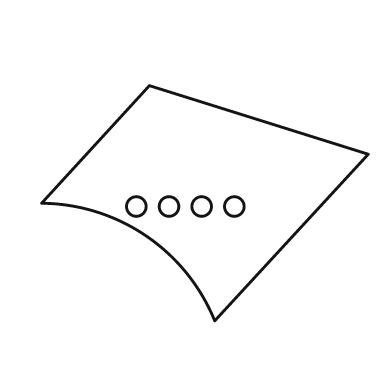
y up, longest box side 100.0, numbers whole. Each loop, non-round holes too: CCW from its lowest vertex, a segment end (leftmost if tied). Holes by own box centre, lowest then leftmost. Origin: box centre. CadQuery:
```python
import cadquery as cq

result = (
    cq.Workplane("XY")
    .moveTo(3.0, -36.0)
    .lineTo(50.0, 15.0)
    .lineTo(-17.0, 36.0)
    .lineTo(-50.0, 0.0)
    .threePointArc((-18.0, -10.0), (3.0, -36.0))
    .close()
    .moveTo(-21.0, -1.0)
    .circle(3.0)
    .moveTo(-11.0, -1.0)
    .circle(3.0)
    .moveTo(-1.0, -1.0)
    .circle(3.0)
    .moveTo(9.0, -1.0)
    .circle(3.0)
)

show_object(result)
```